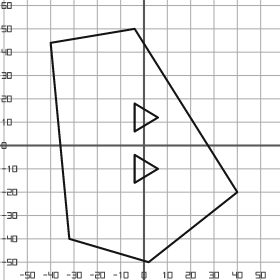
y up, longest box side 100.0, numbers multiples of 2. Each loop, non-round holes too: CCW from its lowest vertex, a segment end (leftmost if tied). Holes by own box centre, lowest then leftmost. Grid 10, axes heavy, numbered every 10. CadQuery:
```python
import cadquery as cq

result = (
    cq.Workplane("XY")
    .moveTo(2.0, -50.0)
    .lineTo(40.0, -20.0)
    .lineTo(-4.0, 50.0)
    .lineTo(-40.0, 44.0)
    .lineTo(-32.0, -40.0)
    .close()
    .moveTo(-4.0, -16.0)
    .lineTo(6.0, -10.0)
    .lineTo(-4.0, -4.0)
    .close()
    .moveTo(-4.0, 6.0)
    .lineTo(6.0, 12.0)
    .lineTo(-4.0, 18.0)
    .close()
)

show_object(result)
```